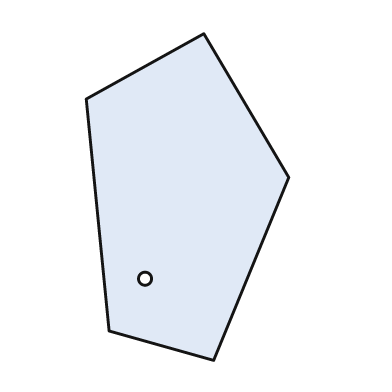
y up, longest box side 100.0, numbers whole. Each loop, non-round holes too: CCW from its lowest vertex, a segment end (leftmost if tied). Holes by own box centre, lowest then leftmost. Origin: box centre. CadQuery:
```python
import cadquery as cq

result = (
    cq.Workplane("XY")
    .moveTo(8.0, -50.0)
    .lineTo(31.0, 6.0)
    .lineTo(5.0, 50.0)
    .lineTo(-31.0, 30.0)
    .lineTo(-24.0, -41.0)
    .close()
    .moveTo(-13.0, -25.0)
    .circle(2.0)
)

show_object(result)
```